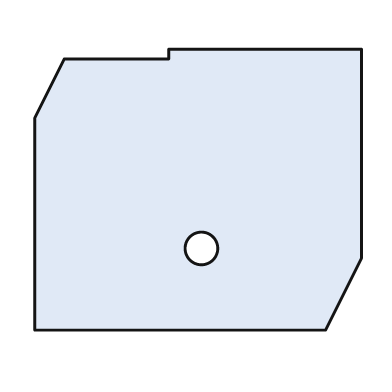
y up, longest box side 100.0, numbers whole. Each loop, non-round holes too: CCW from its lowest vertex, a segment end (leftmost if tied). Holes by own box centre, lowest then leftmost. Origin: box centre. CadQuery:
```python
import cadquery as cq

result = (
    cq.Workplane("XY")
    .moveTo(-50.0, -43.0)
    .lineTo(39.0, -43.0)
    .lineTo(50.0, -21.0)
    .lineTo(50.0, 43.0)
    .lineTo(-9.0, 43.0)
    .lineTo(-9.0, 40.0)
    .lineTo(-41.0, 40.0)
    .lineTo(-50.0, 22.0)
    .close()
    .moveTo(1.0, -18.0)
    .circle(5.0)
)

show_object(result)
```